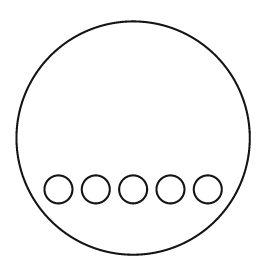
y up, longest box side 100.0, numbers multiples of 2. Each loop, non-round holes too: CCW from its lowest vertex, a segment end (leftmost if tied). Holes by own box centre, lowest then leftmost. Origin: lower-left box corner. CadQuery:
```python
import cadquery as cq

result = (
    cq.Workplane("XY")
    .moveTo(50.0, 50.0)
    .circle(50.0)
    .moveTo(18.0, 28.0)
    .circle(6.0)
    .moveTo(34.0, 28.0)
    .circle(6.0)
    .moveTo(50.0, 28.0)
    .circle(6.0)
    .moveTo(66.0, 28.0)
    .circle(6.0)
    .moveTo(82.0, 28.0)
    .circle(6.0)
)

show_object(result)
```